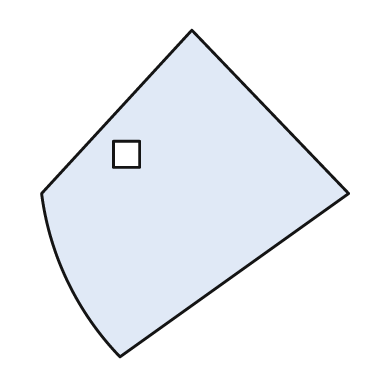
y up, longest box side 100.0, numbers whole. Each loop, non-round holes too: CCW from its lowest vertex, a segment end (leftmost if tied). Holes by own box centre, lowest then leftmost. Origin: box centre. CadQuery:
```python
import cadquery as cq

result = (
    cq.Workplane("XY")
    .moveTo(-23.0, -50.0)
    .lineTo(47.0, 0.0)
    .lineTo(-1.0, 50.0)
    .lineTo(-47.0, 0.0)
    .threePointArc((-39.0, -27.0), (-23.0, -50.0))
    .close()
    .moveTo(-25.0, 8.0)
    .lineTo(-17.0, 8.0)
    .lineTo(-17.0, 16.0)
    .lineTo(-25.0, 16.0)
    .close()
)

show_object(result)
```